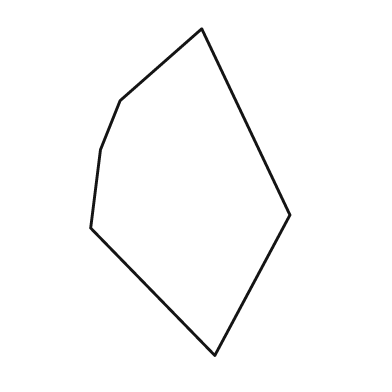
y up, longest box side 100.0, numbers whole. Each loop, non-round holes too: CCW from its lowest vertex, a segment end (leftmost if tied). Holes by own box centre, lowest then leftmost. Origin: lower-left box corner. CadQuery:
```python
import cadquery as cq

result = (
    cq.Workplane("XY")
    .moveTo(38.0, 0.0)
    .lineTo(61.0, 43.0)
    .lineTo(34.0, 100.0)
    .lineTo(9.0, 78.0)
    .lineTo(3.0, 63.0)
    .lineTo(0.0, 39.0)
    .close()
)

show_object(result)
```